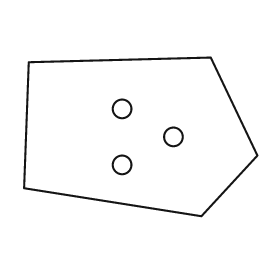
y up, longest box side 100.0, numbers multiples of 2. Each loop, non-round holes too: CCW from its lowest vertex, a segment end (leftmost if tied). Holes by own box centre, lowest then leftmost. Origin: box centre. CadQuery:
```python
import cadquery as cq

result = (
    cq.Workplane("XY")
    .moveTo(26.0, -34.0)
    .lineTo(50.0, -8.0)
    .lineTo(30.0, 34.0)
    .lineTo(-48.0, 32.0)
    .lineTo(-50.0, -22.0)
    .close()
    .moveTo(-8.0, -12.0)
    .circle(4.0)
    .moveTo(14.0, 0.0)
    .circle(4.0)
    .moveTo(-8.0, 12.0)
    .circle(4.0)
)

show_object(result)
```